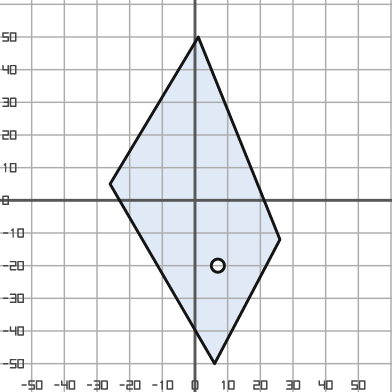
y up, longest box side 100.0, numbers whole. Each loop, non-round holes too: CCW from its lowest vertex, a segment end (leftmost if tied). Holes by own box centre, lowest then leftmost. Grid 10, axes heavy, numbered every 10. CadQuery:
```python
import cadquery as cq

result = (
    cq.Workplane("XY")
    .moveTo(6.0, -50.0)
    .lineTo(26.0, -12.0)
    .lineTo(1.0, 50.0)
    .lineTo(-26.0, 5.0)
    .close()
    .moveTo(7.0, -20.0)
    .circle(2.0)
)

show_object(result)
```